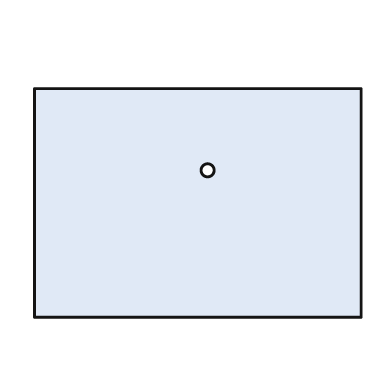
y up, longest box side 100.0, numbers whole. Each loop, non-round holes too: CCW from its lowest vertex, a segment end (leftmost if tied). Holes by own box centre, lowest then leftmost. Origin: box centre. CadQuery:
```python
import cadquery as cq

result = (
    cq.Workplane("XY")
    .moveTo(-50.0, -35.0)
    .lineTo(50.0, -35.0)
    .lineTo(50.0, 35.0)
    .lineTo(-50.0, 35.0)
    .close()
    .moveTo(3.0, 10.0)
    .circle(2.0)
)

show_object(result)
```